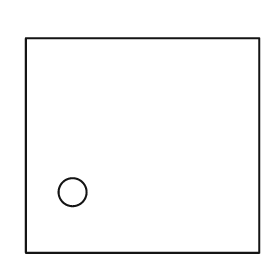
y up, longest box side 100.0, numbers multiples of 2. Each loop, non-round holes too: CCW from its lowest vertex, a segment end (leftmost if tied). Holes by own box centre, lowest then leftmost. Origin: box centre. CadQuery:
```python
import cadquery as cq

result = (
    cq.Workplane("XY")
    .moveTo(-50.0, -46.0)
    .lineTo(50.0, -46.0)
    .lineTo(50.0, 46.0)
    .lineTo(-50.0, 46.0)
    .close()
    .moveTo(-30.0, -20.0)
    .circle(6.0)
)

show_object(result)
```